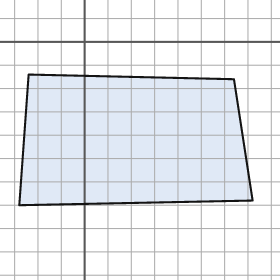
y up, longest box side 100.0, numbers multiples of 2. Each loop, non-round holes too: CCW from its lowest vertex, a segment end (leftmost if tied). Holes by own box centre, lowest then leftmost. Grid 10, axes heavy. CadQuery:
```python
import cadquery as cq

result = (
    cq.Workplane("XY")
    .moveTo(-28.0, -70.0)
    .lineTo(72.0, -68.0)
    .lineTo(64.0, -16.0)
    .lineTo(-24.0, -14.0)
    .close()
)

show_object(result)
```